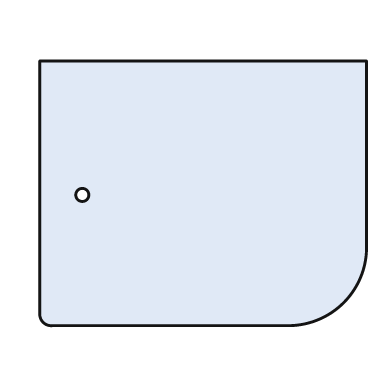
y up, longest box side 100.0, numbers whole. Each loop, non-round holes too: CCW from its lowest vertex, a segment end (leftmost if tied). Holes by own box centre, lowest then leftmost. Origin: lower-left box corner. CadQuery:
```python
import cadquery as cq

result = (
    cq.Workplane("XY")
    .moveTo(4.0, 0.0)
    .lineTo(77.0, 0.0)
    .threePointArc((93.0, 7.0), (100.0, 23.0))
    .lineTo(100.0, 81.0)
    .lineTo(0.0, 81.0)
    .lineTo(0.0, 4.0)
    .threePointArc((1.0, 1.0), (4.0, 0.0))
    .close()
    .moveTo(13.0, 40.0)
    .circle(2.0)
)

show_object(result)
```